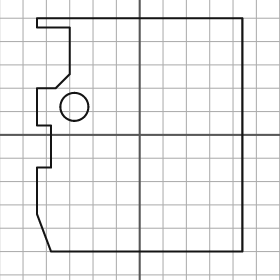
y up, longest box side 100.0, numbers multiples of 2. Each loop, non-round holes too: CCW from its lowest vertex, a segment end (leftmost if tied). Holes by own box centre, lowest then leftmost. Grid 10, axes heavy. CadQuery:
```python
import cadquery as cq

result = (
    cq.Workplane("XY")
    .moveTo(-38.0, -50.0)
    .lineTo(44.0, -50.0)
    .lineTo(44.0, 50.0)
    .lineTo(-44.0, 50.0)
    .lineTo(-44.0, 46.0)
    .lineTo(-30.0, 46.0)
    .lineTo(-30.0, 26.0)
    .lineTo(-36.0, 20.0)
    .lineTo(-44.0, 20.0)
    .lineTo(-44.0, 4.0)
    .lineTo(-38.0, 4.0)
    .lineTo(-38.0, -14.0)
    .lineTo(-44.0, -14.0)
    .lineTo(-44.0, -34.0)
    .close()
    .moveTo(-28.0, 12.0)
    .circle(6.0)
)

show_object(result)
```